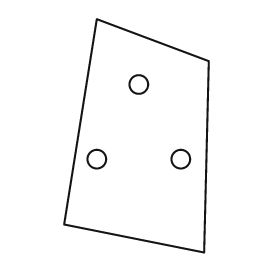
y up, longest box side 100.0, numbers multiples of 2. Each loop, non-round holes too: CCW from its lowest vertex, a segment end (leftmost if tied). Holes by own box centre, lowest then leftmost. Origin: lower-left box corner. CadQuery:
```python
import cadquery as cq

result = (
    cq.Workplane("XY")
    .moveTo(60.0, 0.0)
    .lineTo(62.0, 82.0)
    .lineTo(14.0, 100.0)
    .lineTo(0.0, 12.0)
    .close()
    .moveTo(14.0, 40.0)
    .circle(4.0)
    .moveTo(50.0, 40.0)
    .circle(4.0)
    .moveTo(32.0, 72.0)
    .circle(4.0)
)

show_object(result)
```